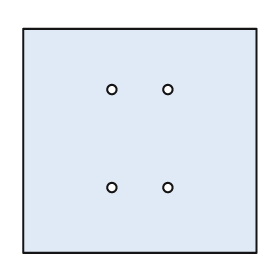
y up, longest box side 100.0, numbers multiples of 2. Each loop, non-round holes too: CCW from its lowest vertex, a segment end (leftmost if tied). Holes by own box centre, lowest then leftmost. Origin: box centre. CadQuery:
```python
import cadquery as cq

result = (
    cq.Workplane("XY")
    .moveTo(-50.0, -48.0)
    .lineTo(50.0, -48.0)
    .lineTo(50.0, 48.0)
    .lineTo(-50.0, 48.0)
    .close()
    .moveTo(-12.0, -20.0)
    .circle(2.0)
    .moveTo(12.0, -20.0)
    .circle(2.0)
    .moveTo(-12.0, 22.0)
    .circle(2.0)
    .moveTo(12.0, 22.0)
    .circle(2.0)
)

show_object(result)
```